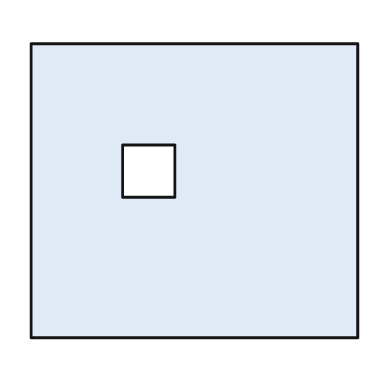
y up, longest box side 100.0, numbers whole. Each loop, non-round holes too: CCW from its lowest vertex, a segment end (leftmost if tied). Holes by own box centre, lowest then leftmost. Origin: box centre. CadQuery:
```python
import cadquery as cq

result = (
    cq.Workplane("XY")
    .moveTo(-50.0, -45.0)
    .lineTo(50.0, -45.0)
    .lineTo(50.0, 45.0)
    .lineTo(-50.0, 45.0)
    .close()
    .moveTo(-22.0, -2.0)
    .lineTo(-6.0, -2.0)
    .lineTo(-6.0, 14.0)
    .lineTo(-22.0, 14.0)
    .close()
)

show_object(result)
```